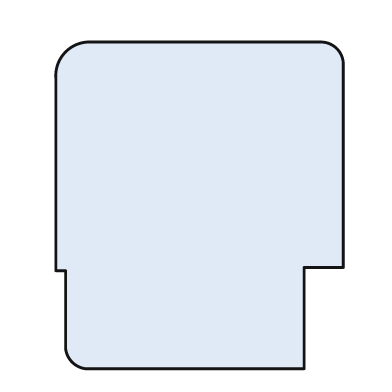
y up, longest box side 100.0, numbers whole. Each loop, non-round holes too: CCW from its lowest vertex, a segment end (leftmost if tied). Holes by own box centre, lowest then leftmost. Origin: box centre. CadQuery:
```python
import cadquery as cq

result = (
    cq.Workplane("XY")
    .moveTo(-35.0, -50.0)
    .lineTo(32.0, -50.0)
    .lineTo(32.0, -19.0)
    .lineTo(44.0, -19.0)
    .lineTo(44.0, 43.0)
    .threePointArc((42.0, 48.0), (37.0, 50.0))
    .lineTo(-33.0, 50.0)
    .threePointArc((-41.0, 47.0), (-44.0, 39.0))
    .lineTo(-44.0, -20.0)
    .lineTo(-41.0, -20.0)
    .lineTo(-41.0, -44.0)
    .threePointArc((-39.0, -48.0), (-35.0, -50.0))
    .close()
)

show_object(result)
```